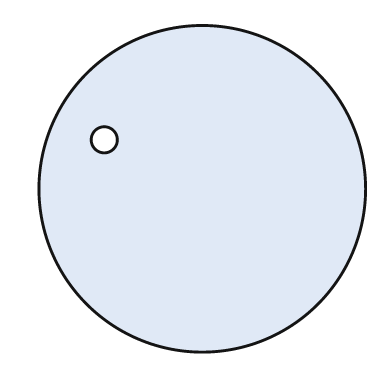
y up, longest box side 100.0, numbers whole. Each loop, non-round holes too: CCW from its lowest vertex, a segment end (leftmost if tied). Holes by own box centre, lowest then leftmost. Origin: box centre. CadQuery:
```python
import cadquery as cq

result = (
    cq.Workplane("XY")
    .moveTo(0.0, 0.0)
    .circle(50.0)
    .moveTo(-30.0, 15.0)
    .circle(4.0)
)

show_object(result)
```